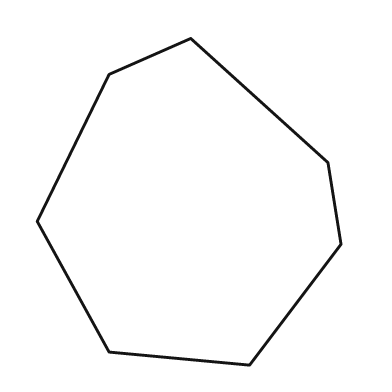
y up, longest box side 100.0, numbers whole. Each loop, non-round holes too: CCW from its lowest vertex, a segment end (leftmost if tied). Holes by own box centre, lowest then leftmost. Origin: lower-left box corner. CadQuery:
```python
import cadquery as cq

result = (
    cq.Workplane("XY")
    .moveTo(65.0, 0.0)
    .lineTo(93.0, 37.0)
    .lineTo(89.0, 62.0)
    .lineTo(47.0, 100.0)
    .lineTo(22.0, 89.0)
    .lineTo(0.0, 44.0)
    .lineTo(22.0, 4.0)
    .close()
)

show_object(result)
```